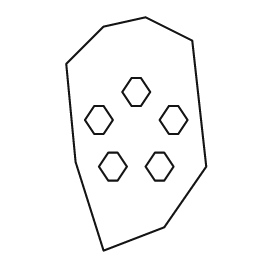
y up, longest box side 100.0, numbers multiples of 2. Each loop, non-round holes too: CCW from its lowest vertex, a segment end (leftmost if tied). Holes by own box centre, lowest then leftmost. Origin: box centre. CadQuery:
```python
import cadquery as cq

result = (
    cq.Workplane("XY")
    .moveTo(-14.0, -50.0)
    .lineTo(12.0, -40.0)
    .lineTo(30.0, -14.0)
    .lineTo(24.0, 40.0)
    .lineTo(4.0, 50.0)
    .lineTo(-14.0, 46.0)
    .lineTo(-30.0, 30.0)
    .lineTo(-26.0, -12.0)
    .close()
    .moveTo(-12.0, -20.0)
    .lineTo(-8.0, -20.0)
    .lineTo(-4.0, -14.0)
    .lineTo(-8.0, -8.0)
    .lineTo(-12.0, -8.0)
    .lineTo(-16.0, -14.0)
    .close()
    .moveTo(8.0, -20.0)
    .lineTo(12.0, -20.0)
    .lineTo(16.0, -14.0)
    .lineTo(12.0, -8.0)
    .lineTo(8.0, -8.0)
    .lineTo(4.0, -14.0)
    .close()
    .moveTo(-18.0, 0.0)
    .lineTo(-14.0, 0.0)
    .lineTo(-10.0, 6.0)
    .lineTo(-14.0, 12.0)
    .lineTo(-18.0, 12.0)
    .lineTo(-22.0, 6.0)
    .close()
    .moveTo(14.0, 0.0)
    .lineTo(18.0, 0.0)
    .lineTo(22.0, 6.0)
    .lineTo(18.0, 12.0)
    .lineTo(14.0, 12.0)
    .lineTo(10.0, 6.0)
    .close()
    .moveTo(-2.0, 12.0)
    .lineTo(2.0, 12.0)
    .lineTo(6.0, 18.0)
    .lineTo(2.0, 24.0)
    .lineTo(-2.0, 24.0)
    .lineTo(-6.0, 18.0)
    .close()
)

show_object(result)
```